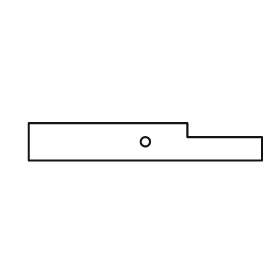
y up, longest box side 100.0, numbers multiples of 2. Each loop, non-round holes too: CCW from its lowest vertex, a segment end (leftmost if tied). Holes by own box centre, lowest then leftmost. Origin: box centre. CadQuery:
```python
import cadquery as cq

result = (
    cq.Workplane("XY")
    .moveTo(-50.0, -8.0)
    .lineTo(50.0, -8.0)
    .lineTo(50.0, 2.0)
    .lineTo(18.0, 2.0)
    .lineTo(18.0, 8.0)
    .lineTo(-50.0, 8.0)
    .close()
    .moveTo(0.0, 0.0)
    .circle(2.0)
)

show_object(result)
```